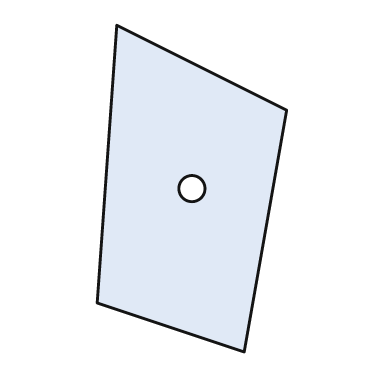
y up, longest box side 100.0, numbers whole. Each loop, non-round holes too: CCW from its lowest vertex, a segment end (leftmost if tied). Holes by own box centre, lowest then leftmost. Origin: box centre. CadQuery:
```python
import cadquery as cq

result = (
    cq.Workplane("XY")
    .moveTo(16.0, -50.0)
    .lineTo(29.0, 24.0)
    .lineTo(-23.0, 50.0)
    .lineTo(-29.0, -35.0)
    .close()
    .moveTo(0.0, 0.0)
    .circle(4.0)
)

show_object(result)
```